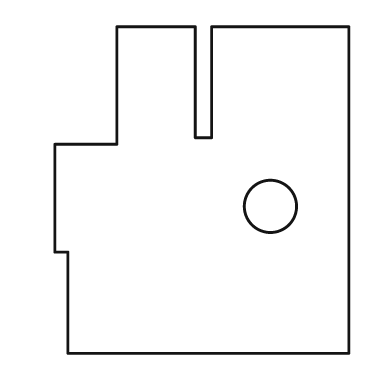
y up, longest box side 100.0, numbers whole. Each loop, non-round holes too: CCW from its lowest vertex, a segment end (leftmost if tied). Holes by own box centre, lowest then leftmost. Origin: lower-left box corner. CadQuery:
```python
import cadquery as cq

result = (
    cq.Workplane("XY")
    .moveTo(4.0, 0.0)
    .lineTo(90.0, 0.0)
    .lineTo(90.0, 100.0)
    .lineTo(48.0, 100.0)
    .lineTo(48.0, 66.0)
    .lineTo(43.0, 66.0)
    .lineTo(43.0, 100.0)
    .lineTo(19.0, 100.0)
    .lineTo(19.0, 64.0)
    .lineTo(0.0, 64.0)
    .lineTo(0.0, 31.0)
    .lineTo(4.0, 31.0)
    .close()
    .moveTo(66.0, 45.0)
    .circle(8.0)
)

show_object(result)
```